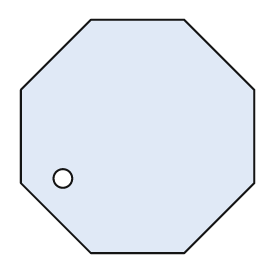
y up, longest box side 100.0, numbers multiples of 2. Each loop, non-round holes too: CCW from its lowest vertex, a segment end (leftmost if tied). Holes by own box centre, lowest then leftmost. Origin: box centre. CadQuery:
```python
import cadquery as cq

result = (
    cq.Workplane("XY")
    .moveTo(-20.0, -50.0)
    .lineTo(20.0, -50.0)
    .lineTo(50.0, -20.0)
    .lineTo(50.0, 20.0)
    .lineTo(20.0, 50.0)
    .lineTo(-20.0, 50.0)
    .lineTo(-50.0, 20.0)
    .lineTo(-50.0, -20.0)
    .close()
    .moveTo(-32.0, -18.0)
    .circle(4.0)
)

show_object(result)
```